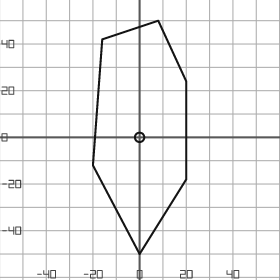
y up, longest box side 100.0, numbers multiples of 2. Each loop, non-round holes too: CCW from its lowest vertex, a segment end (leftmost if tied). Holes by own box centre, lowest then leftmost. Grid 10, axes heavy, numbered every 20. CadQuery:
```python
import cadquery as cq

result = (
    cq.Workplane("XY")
    .moveTo(0.0, -50.0)
    .lineTo(20.0, -18.0)
    .lineTo(20.0, 24.0)
    .lineTo(8.0, 50.0)
    .lineTo(-16.0, 42.0)
    .lineTo(-20.0, -12.0)
    .close()
    .moveTo(0.0, 0.0)
    .circle(2.0)
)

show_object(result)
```